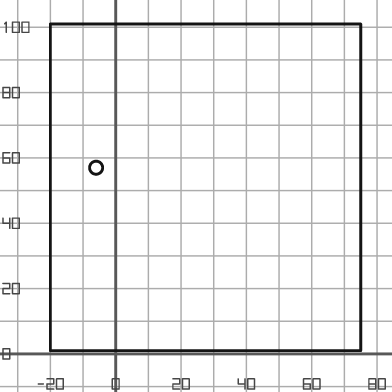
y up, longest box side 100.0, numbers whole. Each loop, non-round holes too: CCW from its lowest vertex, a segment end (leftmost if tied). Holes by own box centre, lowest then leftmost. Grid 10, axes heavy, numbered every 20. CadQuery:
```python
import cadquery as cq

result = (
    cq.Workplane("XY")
    .moveTo(-20.0, 1.0)
    .lineTo(75.0, 1.0)
    .lineTo(75.0, 101.0)
    .lineTo(-20.0, 101.0)
    .close()
    .moveTo(-6.0, 57.0)
    .circle(2.0)
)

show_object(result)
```